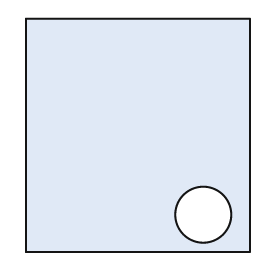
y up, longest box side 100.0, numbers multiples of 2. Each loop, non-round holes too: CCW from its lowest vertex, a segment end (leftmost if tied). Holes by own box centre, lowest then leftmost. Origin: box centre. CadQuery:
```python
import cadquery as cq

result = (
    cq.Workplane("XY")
    .moveTo(-48.0, -50.0)
    .lineTo(48.0, -50.0)
    .lineTo(48.0, 50.0)
    .lineTo(-48.0, 50.0)
    .close()
    .moveTo(28.0, -34.0)
    .circle(12.0)
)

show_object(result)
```